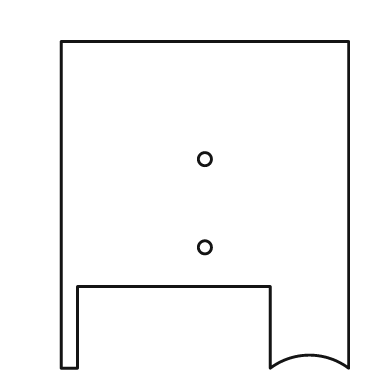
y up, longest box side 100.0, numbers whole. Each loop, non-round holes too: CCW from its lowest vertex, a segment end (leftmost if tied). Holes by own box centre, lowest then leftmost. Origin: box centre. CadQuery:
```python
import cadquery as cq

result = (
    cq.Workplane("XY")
    .moveTo(-44.0, -50.0)
    .lineTo(-39.0, -50.0)
    .lineTo(-39.0, -25.0)
    .lineTo(20.0, -25.0)
    .lineTo(20.0, -50.0)
    .threePointArc((32.0, -46.0), (44.0, -50.0))
    .lineTo(44.0, 50.0)
    .lineTo(-44.0, 50.0)
    .close()
    .moveTo(0.0, -13.0)
    .circle(2.0)
    .moveTo(0.0, 14.0)
    .circle(2.0)
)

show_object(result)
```